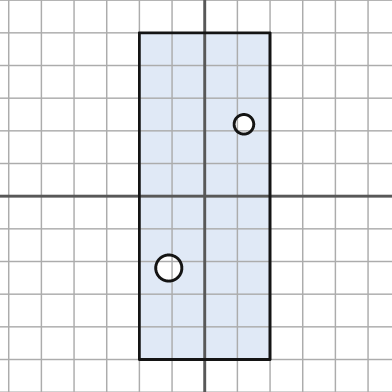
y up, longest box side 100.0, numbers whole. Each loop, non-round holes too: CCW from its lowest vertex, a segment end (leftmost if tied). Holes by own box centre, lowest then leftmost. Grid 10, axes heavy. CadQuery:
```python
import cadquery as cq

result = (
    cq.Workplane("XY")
    .moveTo(-20.0, -50.0)
    .lineTo(20.0, -50.0)
    .lineTo(20.0, 50.0)
    .lineTo(-20.0, 50.0)
    .close()
    .moveTo(-11.0, -22.0)
    .circle(4.0)
    .moveTo(12.0, 22.0)
    .circle(3.0)
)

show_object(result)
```